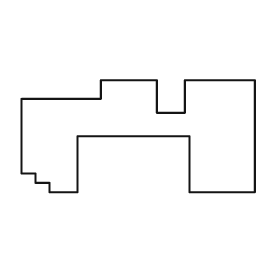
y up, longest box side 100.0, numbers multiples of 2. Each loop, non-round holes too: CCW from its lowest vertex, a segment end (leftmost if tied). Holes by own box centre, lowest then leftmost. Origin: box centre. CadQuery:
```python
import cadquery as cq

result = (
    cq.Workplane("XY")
    .moveTo(-38.0, -24.0)
    .lineTo(-26.0, -24.0)
    .lineTo(-26.0, 0.0)
    .lineTo(22.0, 0.0)
    .lineTo(22.0, -24.0)
    .lineTo(50.0, -24.0)
    .lineTo(50.0, 24.0)
    .lineTo(20.0, 24.0)
    .lineTo(20.0, 10.0)
    .lineTo(8.0, 10.0)
    .lineTo(8.0, 24.0)
    .lineTo(-16.0, 24.0)
    .lineTo(-16.0, 16.0)
    .lineTo(-50.0, 16.0)
    .lineTo(-50.0, -16.0)
    .lineTo(-44.0, -16.0)
    .lineTo(-44.0, -20.0)
    .lineTo(-38.0, -20.0)
    .close()
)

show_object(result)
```